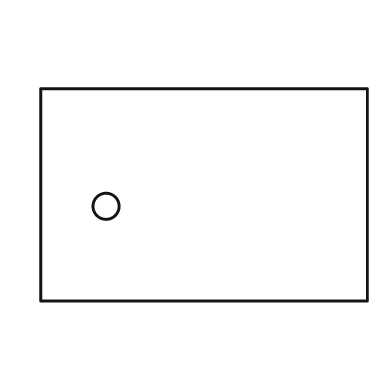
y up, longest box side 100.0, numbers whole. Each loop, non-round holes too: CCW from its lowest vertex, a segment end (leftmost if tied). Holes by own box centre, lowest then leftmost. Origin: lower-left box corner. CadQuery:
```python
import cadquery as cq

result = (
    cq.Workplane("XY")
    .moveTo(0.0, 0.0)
    .lineTo(100.0, 0.0)
    .lineTo(100.0, 65.0)
    .lineTo(0.0, 65.0)
    .close()
    .moveTo(20.0, 29.0)
    .circle(4.0)
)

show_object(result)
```